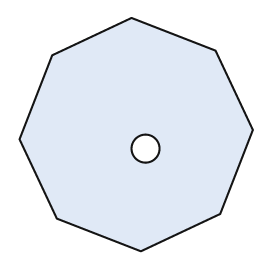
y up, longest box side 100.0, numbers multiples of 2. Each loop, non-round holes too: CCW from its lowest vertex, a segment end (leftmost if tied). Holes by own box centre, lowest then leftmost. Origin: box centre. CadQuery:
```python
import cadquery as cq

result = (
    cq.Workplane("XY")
    .moveTo(2.0, -50.0)
    .lineTo(36.0, -34.0)
    .lineTo(50.0, 2.0)
    .lineTo(34.0, 36.0)
    .lineTo(-2.0, 50.0)
    .lineTo(-36.0, 34.0)
    .lineTo(-50.0, -2.0)
    .lineTo(-34.0, -36.0)
    .close()
    .moveTo(4.0, -6.0)
    .circle(6.0)
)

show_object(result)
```